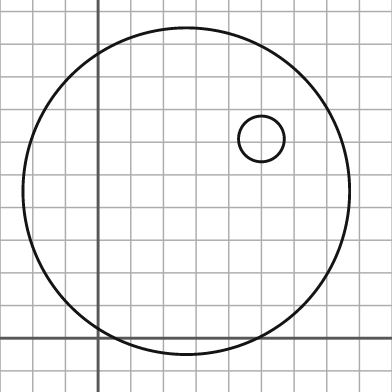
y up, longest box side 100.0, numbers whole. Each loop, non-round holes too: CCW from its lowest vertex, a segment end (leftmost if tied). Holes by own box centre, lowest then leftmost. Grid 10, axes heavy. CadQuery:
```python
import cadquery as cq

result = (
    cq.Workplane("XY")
    .moveTo(27.0, 45.0)
    .circle(50.0)
    .moveTo(50.0, 61.0)
    .circle(7.0)
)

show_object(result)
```